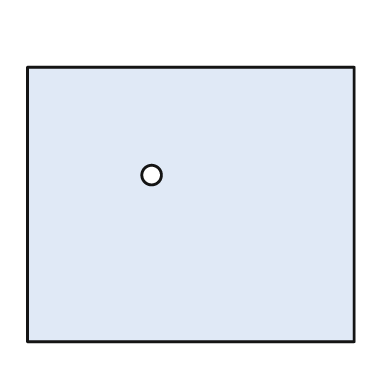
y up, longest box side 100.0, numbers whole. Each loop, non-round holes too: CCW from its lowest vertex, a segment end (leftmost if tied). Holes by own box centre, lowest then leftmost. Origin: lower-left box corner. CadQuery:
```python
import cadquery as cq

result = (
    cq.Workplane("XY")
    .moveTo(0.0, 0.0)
    .lineTo(100.0, 0.0)
    .lineTo(100.0, 84.0)
    .lineTo(0.0, 84.0)
    .close()
    .moveTo(38.0, 51.0)
    .circle(3.0)
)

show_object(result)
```